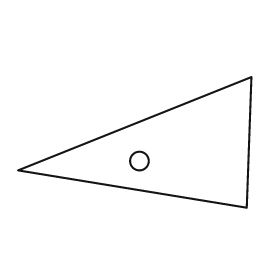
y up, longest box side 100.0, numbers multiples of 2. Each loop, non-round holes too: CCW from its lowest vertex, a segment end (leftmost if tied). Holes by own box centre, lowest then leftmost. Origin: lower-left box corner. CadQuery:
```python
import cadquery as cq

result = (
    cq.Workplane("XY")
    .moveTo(98.0, 0.0)
    .lineTo(100.0, 56.0)
    .lineTo(0.0, 16.0)
    .close()
    .moveTo(52.0, 20.0)
    .circle(4.0)
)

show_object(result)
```